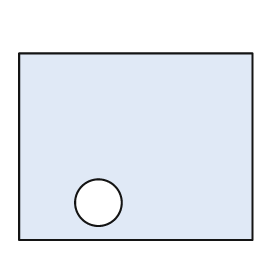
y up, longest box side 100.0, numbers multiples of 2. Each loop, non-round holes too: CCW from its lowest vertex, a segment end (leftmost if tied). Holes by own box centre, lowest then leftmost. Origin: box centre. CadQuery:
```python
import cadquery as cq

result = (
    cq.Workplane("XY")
    .moveTo(-50.0, -40.0)
    .lineTo(50.0, -40.0)
    .lineTo(50.0, 40.0)
    .lineTo(-50.0, 40.0)
    .close()
    .moveTo(-16.0, -24.0)
    .circle(10.0)
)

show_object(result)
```